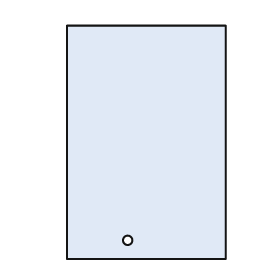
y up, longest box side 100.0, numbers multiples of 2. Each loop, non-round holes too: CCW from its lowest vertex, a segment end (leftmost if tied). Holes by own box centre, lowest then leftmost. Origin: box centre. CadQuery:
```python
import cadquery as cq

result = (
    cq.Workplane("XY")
    .moveTo(-34.0, -50.0)
    .lineTo(34.0, -50.0)
    .lineTo(34.0, 50.0)
    .lineTo(-34.0, 50.0)
    .close()
    .moveTo(-8.0, -42.0)
    .circle(2.0)
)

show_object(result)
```